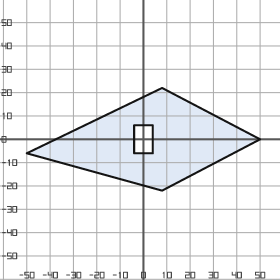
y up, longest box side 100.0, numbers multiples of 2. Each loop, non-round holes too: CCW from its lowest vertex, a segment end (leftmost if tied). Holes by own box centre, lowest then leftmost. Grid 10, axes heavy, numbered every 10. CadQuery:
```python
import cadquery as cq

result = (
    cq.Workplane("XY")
    .moveTo(8.0, -22.0)
    .lineTo(50.0, 0.0)
    .lineTo(8.0, 22.0)
    .lineTo(-50.0, -6.0)
    .close()
    .moveTo(-4.0, -6.0)
    .lineTo(4.0, -6.0)
    .lineTo(4.0, 6.0)
    .lineTo(-4.0, 6.0)
    .close()
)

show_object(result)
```